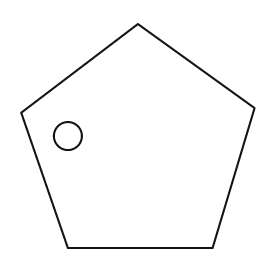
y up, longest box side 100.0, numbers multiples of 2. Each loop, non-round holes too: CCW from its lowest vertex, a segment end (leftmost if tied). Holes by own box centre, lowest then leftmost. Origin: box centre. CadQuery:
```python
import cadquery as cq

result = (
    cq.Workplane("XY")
    .moveTo(-30.0, -48.0)
    .lineTo(32.0, -48.0)
    .lineTo(50.0, 12.0)
    .lineTo(0.0, 48.0)
    .lineTo(-50.0, 10.0)
    .close()
    .moveTo(-30.0, 0.0)
    .circle(6.0)
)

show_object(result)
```